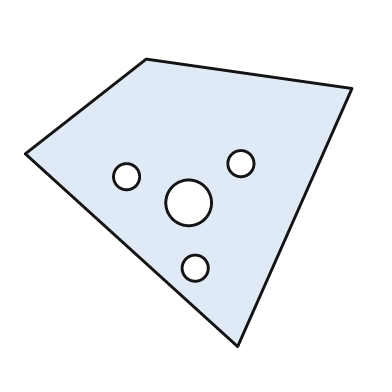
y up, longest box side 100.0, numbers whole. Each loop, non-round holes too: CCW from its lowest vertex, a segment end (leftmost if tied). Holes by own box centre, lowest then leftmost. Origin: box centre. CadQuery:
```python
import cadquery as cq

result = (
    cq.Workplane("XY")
    .moveTo(15.0, -44.0)
    .lineTo(50.0, 35.0)
    .lineTo(-13.0, 44.0)
    .lineTo(-50.0, 15.0)
    .close()
    .moveTo(2.0, -20.0)
    .circle(4.0)
    .moveTo(0.0, 0.0)
    .circle(7.0)
    .moveTo(-19.0, 8.0)
    .circle(4.0)
    .moveTo(16.0, 12.0)
    .circle(4.0)
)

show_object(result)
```